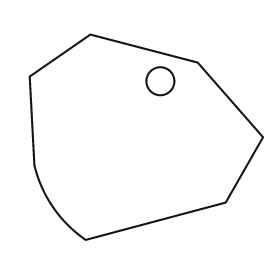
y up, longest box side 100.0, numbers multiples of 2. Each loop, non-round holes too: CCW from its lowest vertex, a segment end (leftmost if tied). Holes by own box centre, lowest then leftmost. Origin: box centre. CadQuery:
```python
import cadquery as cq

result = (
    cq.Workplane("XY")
    .moveTo(-26.0, -44.0)
    .lineTo(34.0, -28.0)
    .lineTo(50.0, 0.0)
    .lineTo(22.0, 32.0)
    .lineTo(-24.0, 44.0)
    .lineTo(-50.0, 26.0)
    .lineTo(-48.0, -12.0)
    .threePointArc((-40.0, -30.0), (-26.0, -44.0))
    .close()
    .moveTo(6.0, 24.0)
    .circle(6.0)
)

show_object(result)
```